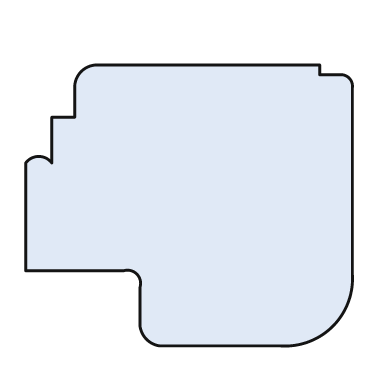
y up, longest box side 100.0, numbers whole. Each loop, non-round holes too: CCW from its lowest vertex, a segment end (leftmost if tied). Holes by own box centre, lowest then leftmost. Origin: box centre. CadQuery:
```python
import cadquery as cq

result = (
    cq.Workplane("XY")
    .moveTo(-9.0, -43.0)
    .lineTo(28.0, -43.0)
    .threePointArc((44.0, -37.0), (50.0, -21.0))
    .lineTo(50.0, 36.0)
    .threePointArc((49.0, 39.0), (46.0, 40.0))
    .lineTo(40.0, 40.0)
    .lineTo(40.0, 43.0)
    .lineTo(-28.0, 43.0)
    .threePointArc((-33.0, 41.0), (-35.0, 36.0))
    .lineTo(-35.0, 27.0)
    .lineTo(-42.0, 27.0)
    .lineTo(-42.0, 13.0)
    .threePointArc((-46.0, 15.0), (-50.0, 13.0))
    .lineTo(-50.0, -20.0)
    .lineTo(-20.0, -20.0)
    .threePointArc((-16.0, -21.0), (-15.0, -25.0))
    .lineTo(-15.0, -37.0)
    .threePointArc((-13.0, -41.0), (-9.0, -43.0))
    .close()
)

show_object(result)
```